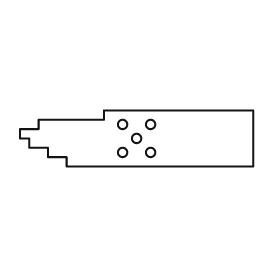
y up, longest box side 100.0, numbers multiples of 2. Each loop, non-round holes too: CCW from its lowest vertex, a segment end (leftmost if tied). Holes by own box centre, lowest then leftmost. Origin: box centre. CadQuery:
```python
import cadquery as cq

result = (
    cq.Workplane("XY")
    .moveTo(-30.0, -12.0)
    .lineTo(50.0, -12.0)
    .lineTo(50.0, 12.0)
    .lineTo(-14.0, 12.0)
    .lineTo(-14.0, 8.0)
    .lineTo(-42.0, 8.0)
    .lineTo(-42.0, 4.0)
    .lineTo(-50.0, 4.0)
    .lineTo(-50.0, 0.0)
    .lineTo(-46.0, 0.0)
    .lineTo(-46.0, -4.0)
    .lineTo(-38.0, -4.0)
    .lineTo(-38.0, -8.0)
    .lineTo(-30.0, -8.0)
    .close()
    .moveTo(-6.0, -6.0)
    .circle(2.0)
    .moveTo(6.0, -6.0)
    .circle(2.0)
    .moveTo(0.0, 0.0)
    .circle(2.0)
    .moveTo(-6.0, 6.0)
    .circle(2.0)
    .moveTo(6.0, 6.0)
    .circle(2.0)
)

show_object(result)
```